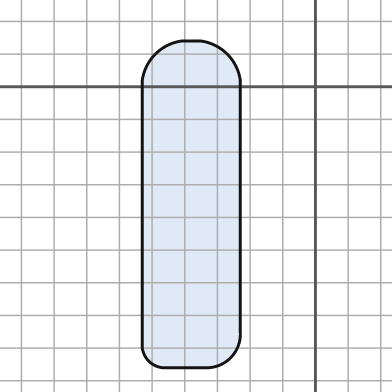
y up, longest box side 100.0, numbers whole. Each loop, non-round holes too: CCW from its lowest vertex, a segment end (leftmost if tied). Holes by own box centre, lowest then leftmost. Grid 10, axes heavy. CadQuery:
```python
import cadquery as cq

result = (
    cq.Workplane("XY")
    .moveTo(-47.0, -86.0)
    .lineTo(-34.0, -86.0)
    .threePointArc((-26.0, -83.0), (-23.0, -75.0))
    .lineTo(-23.0, 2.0)
    .threePointArc((-27.0, 10.0), (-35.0, 14.0))
    .lineTo(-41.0, 14.0)
    .threePointArc((-49.0, 10.0), (-53.0, 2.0))
    .lineTo(-53.0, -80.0)
    .threePointArc((-51.0, -84.0), (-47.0, -86.0))
    .close()
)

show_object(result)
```